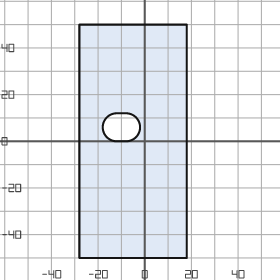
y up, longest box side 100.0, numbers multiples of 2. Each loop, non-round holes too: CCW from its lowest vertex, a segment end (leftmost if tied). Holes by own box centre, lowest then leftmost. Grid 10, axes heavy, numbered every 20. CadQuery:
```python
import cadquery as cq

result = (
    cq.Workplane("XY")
    .moveTo(-28.0, -50.0)
    .lineTo(18.0, -50.0)
    .lineTo(18.0, 50.0)
    .lineTo(-28.0, 50.0)
    .close()
    .moveTo(-12.0, 0.0)
    .lineTo(-8.0, 0.0)
    .threePointArc((-2.0, 6.0), (-8.0, 12.0))
    .lineTo(-12.0, 12.0)
    .threePointArc((-18.0, 6.0), (-12.0, 0.0))
    .close()
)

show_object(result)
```